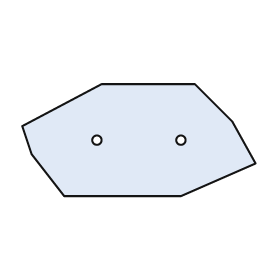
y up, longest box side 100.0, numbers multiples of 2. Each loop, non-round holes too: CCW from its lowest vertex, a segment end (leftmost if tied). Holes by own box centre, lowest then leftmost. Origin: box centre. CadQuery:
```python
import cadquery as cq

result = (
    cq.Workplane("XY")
    .moveTo(-32.0, -24.0)
    .lineTo(18.0, -24.0)
    .lineTo(50.0, -10.0)
    .lineTo(40.0, 8.0)
    .lineTo(24.0, 24.0)
    .lineTo(-16.0, 24.0)
    .lineTo(-50.0, 6.0)
    .lineTo(-46.0, -6.0)
    .close()
    .moveTo(-18.0, 0.0)
    .circle(2.0)
    .moveTo(18.0, 0.0)
    .circle(2.0)
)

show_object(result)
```